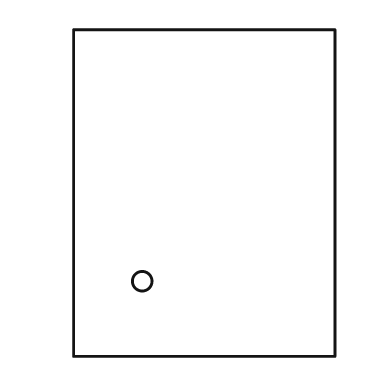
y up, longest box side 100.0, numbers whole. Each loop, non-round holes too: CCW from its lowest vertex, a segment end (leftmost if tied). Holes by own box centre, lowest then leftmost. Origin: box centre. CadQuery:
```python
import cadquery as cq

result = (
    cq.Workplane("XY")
    .moveTo(-40.0, -50.0)
    .lineTo(40.0, -50.0)
    .lineTo(40.0, 50.0)
    .lineTo(-40.0, 50.0)
    .close()
    .moveTo(-19.0, -27.0)
    .circle(3.0)
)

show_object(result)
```